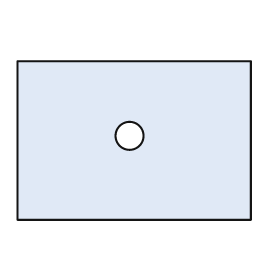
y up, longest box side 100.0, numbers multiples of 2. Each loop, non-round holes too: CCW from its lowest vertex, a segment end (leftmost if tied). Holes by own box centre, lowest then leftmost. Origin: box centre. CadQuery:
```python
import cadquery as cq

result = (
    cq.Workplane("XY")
    .moveTo(-50.0, -34.0)
    .lineTo(50.0, -34.0)
    .lineTo(50.0, 34.0)
    .lineTo(-50.0, 34.0)
    .close()
    .moveTo(-2.0, 2.0)
    .circle(6.0)
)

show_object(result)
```